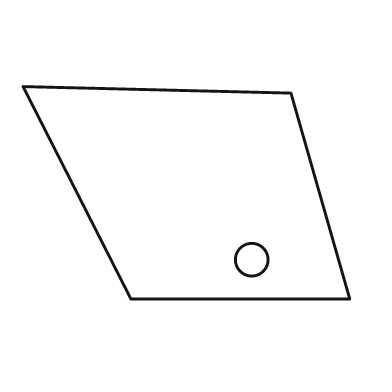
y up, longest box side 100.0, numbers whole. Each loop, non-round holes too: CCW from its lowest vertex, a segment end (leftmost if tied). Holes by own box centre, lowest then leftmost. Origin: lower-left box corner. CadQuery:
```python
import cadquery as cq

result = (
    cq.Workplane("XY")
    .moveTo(33.0, 0.0)
    .lineTo(100.0, 0.0)
    .lineTo(82.0, 63.0)
    .lineTo(0.0, 65.0)
    .close()
    .moveTo(70.0, 12.0)
    .circle(5.0)
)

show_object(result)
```